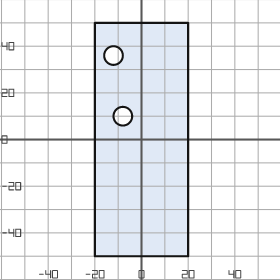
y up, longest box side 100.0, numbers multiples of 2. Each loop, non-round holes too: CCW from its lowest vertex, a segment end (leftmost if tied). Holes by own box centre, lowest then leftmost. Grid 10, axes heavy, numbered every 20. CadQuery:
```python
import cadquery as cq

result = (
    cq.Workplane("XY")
    .moveTo(-20.0, -50.0)
    .lineTo(20.0, -50.0)
    .lineTo(20.0, 50.0)
    .lineTo(-20.0, 50.0)
    .close()
    .moveTo(-8.0, 10.0)
    .circle(4.0)
    .moveTo(-12.0, 36.0)
    .circle(4.0)
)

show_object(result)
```